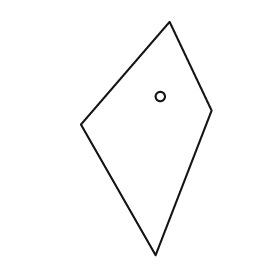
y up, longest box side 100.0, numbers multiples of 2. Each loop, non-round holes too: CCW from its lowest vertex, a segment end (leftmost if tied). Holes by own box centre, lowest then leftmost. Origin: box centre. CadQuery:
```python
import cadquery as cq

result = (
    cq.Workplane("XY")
    .moveTo(4.0, -50.0)
    .lineTo(28.0, 12.0)
    .lineTo(10.0, 50.0)
    .lineTo(-28.0, 6.0)
    .close()
    .moveTo(6.0, 18.0)
    .circle(2.0)
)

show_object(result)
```